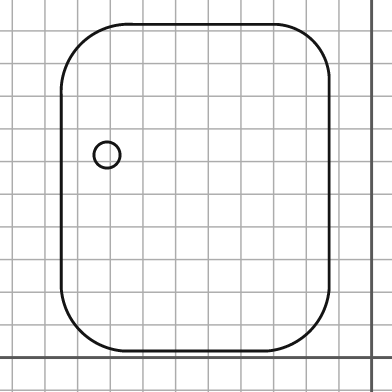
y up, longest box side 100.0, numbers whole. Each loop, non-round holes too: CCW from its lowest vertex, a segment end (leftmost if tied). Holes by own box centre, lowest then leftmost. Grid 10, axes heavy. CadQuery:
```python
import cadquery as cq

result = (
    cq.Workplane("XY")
    .moveTo(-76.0, 2.0)
    .lineTo(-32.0, 2.0)
    .threePointArc((-19.0, 8.0), (-13.0, 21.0))
    .lineTo(-13.0, 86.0)
    .threePointArc((-18.0, 97.0), (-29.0, 102.0))
    .lineTo(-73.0, 102.0)
    .threePointArc((-89.0, 96.0), (-95.0, 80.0))
    .lineTo(-95.0, 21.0)
    .threePointArc((-89.0, 8.0), (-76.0, 2.0))
    .close()
    .moveTo(-81.0, 62.0)
    .circle(4.0)
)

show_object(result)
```